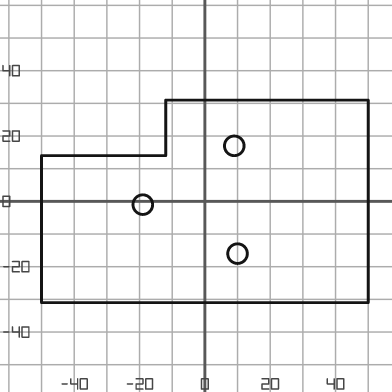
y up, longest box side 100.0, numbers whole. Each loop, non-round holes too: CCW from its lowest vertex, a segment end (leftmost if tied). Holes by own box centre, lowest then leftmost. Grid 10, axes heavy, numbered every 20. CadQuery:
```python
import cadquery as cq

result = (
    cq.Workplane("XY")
    .moveTo(-50.0, -31.0)
    .lineTo(50.0, -31.0)
    .lineTo(50.0, 31.0)
    .lineTo(-12.0, 31.0)
    .lineTo(-12.0, 14.0)
    .lineTo(-50.0, 14.0)
    .close()
    .moveTo(10.0, -16.0)
    .circle(3.0)
    .moveTo(-19.0, -1.0)
    .circle(3.0)
    .moveTo(9.0, 17.0)
    .circle(3.0)
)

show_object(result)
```